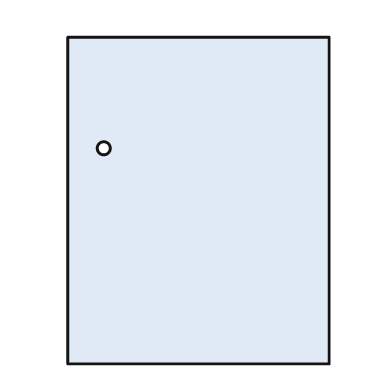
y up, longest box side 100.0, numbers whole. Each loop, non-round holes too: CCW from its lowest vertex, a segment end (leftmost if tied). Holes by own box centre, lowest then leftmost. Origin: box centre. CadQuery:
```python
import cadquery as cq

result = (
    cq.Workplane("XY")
    .moveTo(-40.0, -50.0)
    .lineTo(40.0, -50.0)
    .lineTo(40.0, 50.0)
    .lineTo(-40.0, 50.0)
    .close()
    .moveTo(-29.0, 16.0)
    .circle(2.0)
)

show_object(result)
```